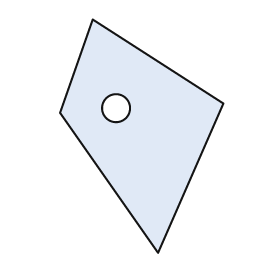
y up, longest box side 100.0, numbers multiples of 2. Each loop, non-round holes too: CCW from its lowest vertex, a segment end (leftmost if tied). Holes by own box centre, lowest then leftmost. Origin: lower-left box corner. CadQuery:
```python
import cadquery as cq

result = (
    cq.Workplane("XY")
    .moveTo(42.0, 0.0)
    .lineTo(70.0, 64.0)
    .lineTo(14.0, 100.0)
    .lineTo(0.0, 60.0)
    .close()
    .moveTo(24.0, 62.0)
    .circle(6.0)
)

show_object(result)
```